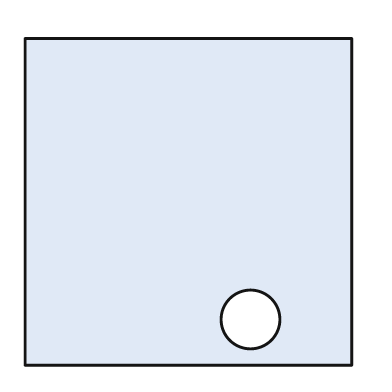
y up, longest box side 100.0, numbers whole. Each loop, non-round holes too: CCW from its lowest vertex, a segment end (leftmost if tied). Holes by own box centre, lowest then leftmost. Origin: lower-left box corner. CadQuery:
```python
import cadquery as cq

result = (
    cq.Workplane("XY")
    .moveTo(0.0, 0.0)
    .lineTo(100.0, 0.0)
    .lineTo(100.0, 100.0)
    .lineTo(0.0, 100.0)
    .close()
    .moveTo(69.0, 14.0)
    .circle(9.0)
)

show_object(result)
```